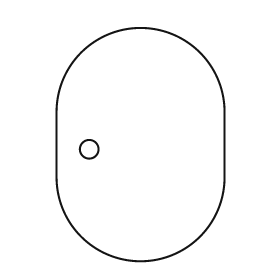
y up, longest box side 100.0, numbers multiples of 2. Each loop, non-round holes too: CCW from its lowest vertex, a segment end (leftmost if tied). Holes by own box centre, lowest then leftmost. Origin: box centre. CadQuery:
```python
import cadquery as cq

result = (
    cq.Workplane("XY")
    .moveTo(-36.0, -14.0)
    .threePointArc((0.0, -50.0), (36.0, -14.0))
    .lineTo(36.0, 14.0)
    .threePointArc((0.0, 50.0), (-36.0, 14.0))
    .close()
    .moveTo(-22.0, -2.0)
    .circle(4.0)
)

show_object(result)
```